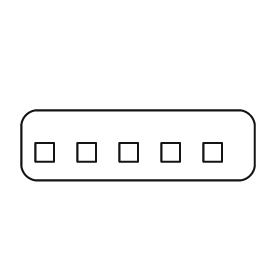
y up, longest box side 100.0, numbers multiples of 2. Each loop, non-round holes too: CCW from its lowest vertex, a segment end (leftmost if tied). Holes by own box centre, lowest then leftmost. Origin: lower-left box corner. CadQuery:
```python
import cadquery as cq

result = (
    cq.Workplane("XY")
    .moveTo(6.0, 0.0)
    .lineTo(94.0, 0.0)
    .threePointArc((98.0, 2.0), (100.0, 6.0))
    .lineTo(100.0, 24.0)
    .threePointArc((98.0, 28.0), (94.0, 30.0))
    .lineTo(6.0, 30.0)
    .threePointArc((2.0, 28.0), (0.0, 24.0))
    .lineTo(0.0, 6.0)
    .threePointArc((2.0, 2.0), (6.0, 0.0))
    .close()
    .moveTo(6.0, 8.0)
    .lineTo(14.0, 8.0)
    .lineTo(14.0, 16.0)
    .lineTo(6.0, 16.0)
    .close()
    .moveTo(24.0, 8.0)
    .lineTo(32.0, 8.0)
    .lineTo(32.0, 16.0)
    .lineTo(24.0, 16.0)
    .close()
    .moveTo(42.0, 8.0)
    .lineTo(50.0, 8.0)
    .lineTo(50.0, 16.0)
    .lineTo(42.0, 16.0)
    .close()
    .moveTo(60.0, 8.0)
    .lineTo(68.0, 8.0)
    .lineTo(68.0, 16.0)
    .lineTo(60.0, 16.0)
    .close()
    .moveTo(78.0, 8.0)
    .lineTo(86.0, 8.0)
    .lineTo(86.0, 16.0)
    .lineTo(78.0, 16.0)
    .close()
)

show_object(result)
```